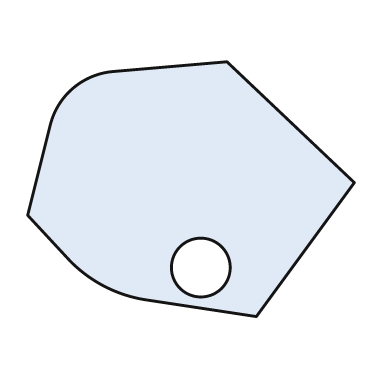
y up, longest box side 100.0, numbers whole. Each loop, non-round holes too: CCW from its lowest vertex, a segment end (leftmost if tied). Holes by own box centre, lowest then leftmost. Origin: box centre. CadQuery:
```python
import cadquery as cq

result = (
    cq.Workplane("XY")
    .moveTo(20.0, -39.0)
    .lineTo(50.0, 2.0)
    .lineTo(11.0, 39.0)
    .lineTo(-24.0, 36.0)
    .threePointArc((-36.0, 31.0), (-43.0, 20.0))
    .lineTo(-50.0, -8.0)
    .lineTo(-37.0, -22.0)
    .threePointArc((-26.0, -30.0), (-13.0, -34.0))
    .close()
    .moveTo(3.0, -24.0)
    .circle(9.0)
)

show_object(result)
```